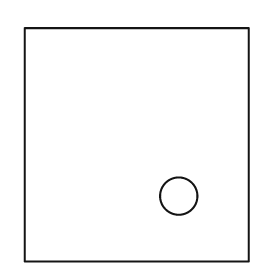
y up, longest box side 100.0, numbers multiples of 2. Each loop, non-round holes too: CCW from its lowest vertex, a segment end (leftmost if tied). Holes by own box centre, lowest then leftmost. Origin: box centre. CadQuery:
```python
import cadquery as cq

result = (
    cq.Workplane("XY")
    .moveTo(-48.0, -50.0)
    .lineTo(48.0, -50.0)
    .lineTo(48.0, 50.0)
    .lineTo(-48.0, 50.0)
    .close()
    .moveTo(18.0, -22.0)
    .circle(8.0)
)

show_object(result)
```